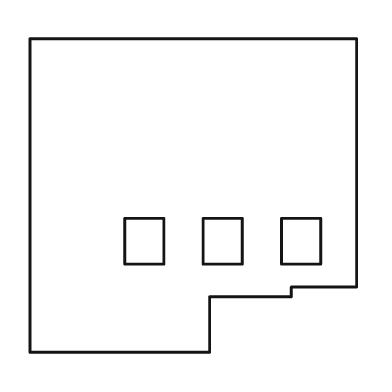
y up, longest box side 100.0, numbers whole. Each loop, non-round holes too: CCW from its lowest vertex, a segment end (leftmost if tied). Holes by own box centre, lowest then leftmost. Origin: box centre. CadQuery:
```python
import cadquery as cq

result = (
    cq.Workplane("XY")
    .moveTo(-50.0, -48.0)
    .lineTo(5.0, -48.0)
    .lineTo(5.0, -31.0)
    .lineTo(30.0, -31.0)
    .lineTo(30.0, -28.0)
    .lineTo(50.0, -28.0)
    .lineTo(50.0, 48.0)
    .lineTo(-50.0, 48.0)
    .close()
    .moveTo(-21.0, -21.0)
    .lineTo(-9.0, -21.0)
    .lineTo(-9.0, -7.0)
    .lineTo(-21.0, -7.0)
    .close()
    .moveTo(3.0, -21.0)
    .lineTo(15.0, -21.0)
    .lineTo(15.0, -7.0)
    .lineTo(3.0, -7.0)
    .close()
    .moveTo(27.0, -21.0)
    .lineTo(39.0, -21.0)
    .lineTo(39.0, -7.0)
    .lineTo(27.0, -7.0)
    .close()
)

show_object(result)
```